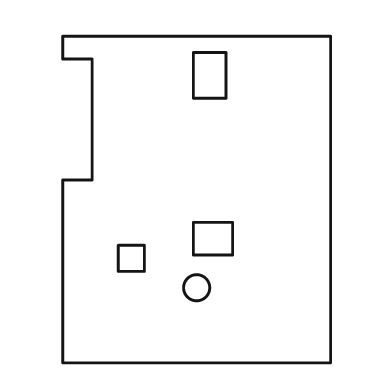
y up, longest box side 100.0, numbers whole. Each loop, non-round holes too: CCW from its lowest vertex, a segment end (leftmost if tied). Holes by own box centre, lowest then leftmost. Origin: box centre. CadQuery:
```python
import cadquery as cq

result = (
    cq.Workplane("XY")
    .moveTo(-41.0, -50.0)
    .lineTo(41.0, -50.0)
    .lineTo(41.0, 50.0)
    .lineTo(-41.0, 50.0)
    .lineTo(-41.0, 43.0)
    .lineTo(-32.0, 43.0)
    .lineTo(-32.0, 6.0)
    .lineTo(-41.0, 6.0)
    .close()
    .moveTo(0.0, -27.0)
    .circle(4.0)
    .moveTo(-24.0, -22.0)
    .lineTo(-16.0, -22.0)
    .lineTo(-16.0, -14.0)
    .lineTo(-24.0, -14.0)
    .close()
    .moveTo(-1.0, -17.0)
    .lineTo(11.0, -17.0)
    .lineTo(11.0, -7.0)
    .lineTo(-1.0, -7.0)
    .close()
    .moveTo(-1.0, 31.0)
    .lineTo(9.0, 31.0)
    .lineTo(9.0, 45.0)
    .lineTo(-1.0, 45.0)
    .close()
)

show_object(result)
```